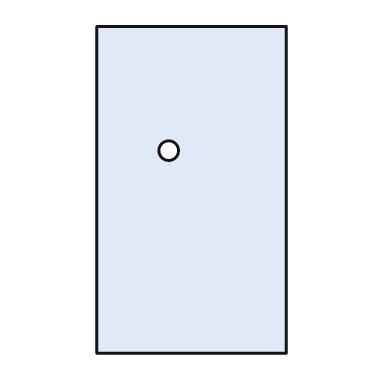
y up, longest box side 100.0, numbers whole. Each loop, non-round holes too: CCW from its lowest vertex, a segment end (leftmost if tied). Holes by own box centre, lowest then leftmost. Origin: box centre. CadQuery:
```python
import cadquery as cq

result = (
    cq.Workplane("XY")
    .moveTo(-29.0, -50.0)
    .lineTo(29.0, -50.0)
    .lineTo(29.0, 50.0)
    .lineTo(-29.0, 50.0)
    .close()
    .moveTo(-7.0, 12.0)
    .circle(3.0)
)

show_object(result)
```